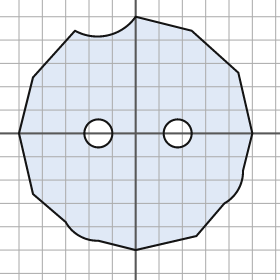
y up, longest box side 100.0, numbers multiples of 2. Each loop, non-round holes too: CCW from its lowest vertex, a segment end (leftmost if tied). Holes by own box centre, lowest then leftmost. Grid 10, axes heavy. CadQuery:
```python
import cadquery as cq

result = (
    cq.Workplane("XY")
    .moveTo(0.0, -50.0)
    .lineTo(26.0, -44.0)
    .lineTo(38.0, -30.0)
    .threePointArc((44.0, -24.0), (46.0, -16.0))
    .lineTo(50.0, 0.0)
    .lineTo(44.0, 26.0)
    .lineTo(24.0, 44.0)
    .lineTo(0.0, 50.0)
    .threePointArc((-12.0, 42.0), (-26.0, 44.0))
    .lineTo(-44.0, 24.0)
    .lineTo(-50.0, 0.0)
    .lineTo(-44.0, -26.0)
    .lineTo(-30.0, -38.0)
    .threePointArc((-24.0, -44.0), (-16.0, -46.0))
    .close()
    .moveTo(-16.0, 0.0)
    .circle(6.0)
    .moveTo(18.0, 0.0)
    .circle(6.0)
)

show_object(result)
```